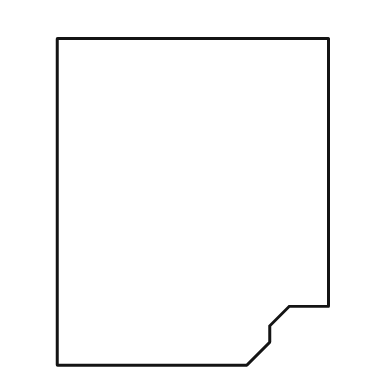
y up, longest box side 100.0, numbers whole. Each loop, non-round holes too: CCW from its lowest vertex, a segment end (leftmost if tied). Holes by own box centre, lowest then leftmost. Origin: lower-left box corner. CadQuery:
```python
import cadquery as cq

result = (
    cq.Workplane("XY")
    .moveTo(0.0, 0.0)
    .lineTo(58.0, 0.0)
    .lineTo(65.0, 7.0)
    .lineTo(65.0, 12.0)
    .lineTo(71.0, 18.0)
    .lineTo(83.0, 18.0)
    .lineTo(83.0, 100.0)
    .lineTo(0.0, 100.0)
    .close()
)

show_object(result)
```